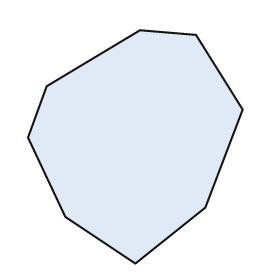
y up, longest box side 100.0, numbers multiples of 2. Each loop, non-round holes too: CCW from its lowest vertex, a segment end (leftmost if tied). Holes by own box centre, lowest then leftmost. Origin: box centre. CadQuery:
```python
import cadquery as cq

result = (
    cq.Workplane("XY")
    .moveTo(0.0, -50.0)
    .lineTo(30.0, -26.0)
    .lineTo(46.0, 16.0)
    .lineTo(26.0, 48.0)
    .lineTo(2.0, 50.0)
    .lineTo(-38.0, 26.0)
    .lineTo(-46.0, 4.0)
    .lineTo(-30.0, -30.0)
    .close()
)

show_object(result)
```